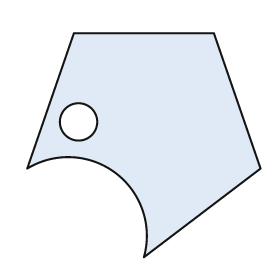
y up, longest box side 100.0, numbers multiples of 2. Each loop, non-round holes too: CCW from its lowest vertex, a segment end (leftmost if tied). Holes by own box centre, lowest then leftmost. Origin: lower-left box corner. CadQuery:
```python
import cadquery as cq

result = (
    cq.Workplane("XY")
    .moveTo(50.0, 0.0)
    .lineTo(100.0, 38.0)
    .lineTo(80.0, 96.0)
    .lineTo(20.0, 96.0)
    .lineTo(0.0, 38.0)
    .threePointArc((38.0, 36.0), (50.0, 0.0))
    .close()
    .moveTo(22.0, 58.0)
    .circle(8.0)
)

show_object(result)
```